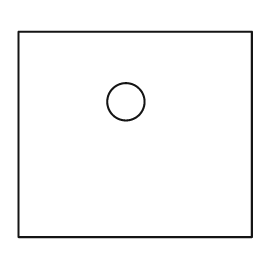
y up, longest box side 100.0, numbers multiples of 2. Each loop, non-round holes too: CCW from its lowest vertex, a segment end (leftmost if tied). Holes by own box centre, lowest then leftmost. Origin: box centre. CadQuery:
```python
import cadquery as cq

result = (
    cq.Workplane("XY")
    .moveTo(-50.0, -44.0)
    .lineTo(50.0, -44.0)
    .lineTo(50.0, 44.0)
    .lineTo(-50.0, 44.0)
    .close()
    .moveTo(-4.0, 14.0)
    .circle(8.0)
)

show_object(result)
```